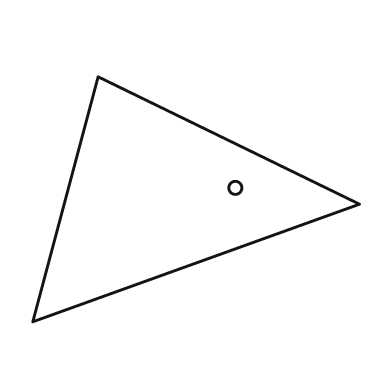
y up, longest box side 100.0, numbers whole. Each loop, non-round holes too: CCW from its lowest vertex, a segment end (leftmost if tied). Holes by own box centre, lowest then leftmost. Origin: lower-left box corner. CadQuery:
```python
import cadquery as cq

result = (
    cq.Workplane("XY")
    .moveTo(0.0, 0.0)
    .lineTo(100.0, 36.0)
    .lineTo(20.0, 75.0)
    .close()
    .moveTo(62.0, 41.0)
    .circle(2.0)
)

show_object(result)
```